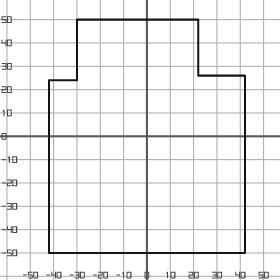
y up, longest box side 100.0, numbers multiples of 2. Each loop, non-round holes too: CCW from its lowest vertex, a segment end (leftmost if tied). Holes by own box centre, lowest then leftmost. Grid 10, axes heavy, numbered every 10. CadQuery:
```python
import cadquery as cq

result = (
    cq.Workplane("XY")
    .moveTo(-42.0, -50.0)
    .lineTo(42.0, -50.0)
    .lineTo(42.0, 26.0)
    .lineTo(22.0, 26.0)
    .lineTo(22.0, 50.0)
    .lineTo(-30.0, 50.0)
    .lineTo(-30.0, 24.0)
    .lineTo(-42.0, 24.0)
    .close()
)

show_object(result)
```